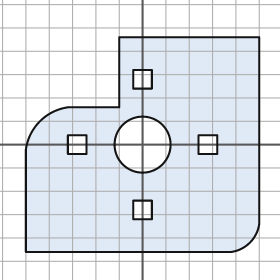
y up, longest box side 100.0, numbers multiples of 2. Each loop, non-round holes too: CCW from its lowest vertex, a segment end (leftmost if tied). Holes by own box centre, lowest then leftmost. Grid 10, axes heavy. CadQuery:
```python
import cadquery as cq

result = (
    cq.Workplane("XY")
    .moveTo(-50.0, -46.0)
    .lineTo(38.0, -46.0)
    .threePointArc((46.0, -42.0), (50.0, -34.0))
    .lineTo(50.0, 46.0)
    .lineTo(-10.0, 46.0)
    .lineTo(-10.0, 16.0)
    .lineTo(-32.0, 16.0)
    .threePointArc((-44.0, 10.0), (-50.0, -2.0))
    .close()
    .moveTo(-4.0, -32.0)
    .lineTo(4.0, -32.0)
    .lineTo(4.0, -24.0)
    .lineTo(-4.0, -24.0)
    .close()
    .moveTo(-32.0, -4.0)
    .lineTo(-24.0, -4.0)
    .lineTo(-24.0, 4.0)
    .lineTo(-32.0, 4.0)
    .close()
    .moveTo(0.0, 0.0)
    .circle(12.0)
    .moveTo(24.0, -4.0)
    .lineTo(32.0, -4.0)
    .lineTo(32.0, 4.0)
    .lineTo(24.0, 4.0)
    .close()
    .moveTo(-4.0, 24.0)
    .lineTo(4.0, 24.0)
    .lineTo(4.0, 32.0)
    .lineTo(-4.0, 32.0)
    .close()
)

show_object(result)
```